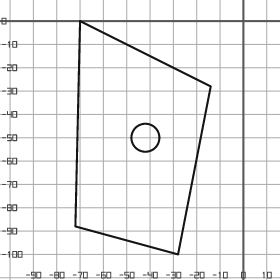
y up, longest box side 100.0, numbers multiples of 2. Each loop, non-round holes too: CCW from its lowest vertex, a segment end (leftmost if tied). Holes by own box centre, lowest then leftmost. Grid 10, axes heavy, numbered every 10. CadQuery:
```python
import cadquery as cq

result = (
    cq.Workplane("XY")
    .moveTo(-28.0, -100.0)
    .lineTo(-14.0, -28.0)
    .lineTo(-70.0, 0.0)
    .lineTo(-72.0, -88.0)
    .close()
    .moveTo(-42.0, -50.0)
    .circle(6.0)
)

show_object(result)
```